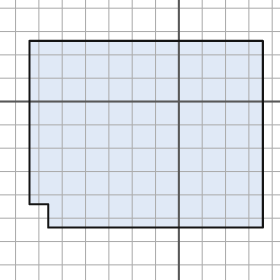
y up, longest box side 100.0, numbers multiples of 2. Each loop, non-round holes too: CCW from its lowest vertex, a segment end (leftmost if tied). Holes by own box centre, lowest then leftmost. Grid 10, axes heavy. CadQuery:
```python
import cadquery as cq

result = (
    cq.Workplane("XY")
    .moveTo(-56.0, -54.0)
    .lineTo(36.0, -54.0)
    .lineTo(36.0, 26.0)
    .lineTo(-64.0, 26.0)
    .lineTo(-64.0, -44.0)
    .lineTo(-56.0, -44.0)
    .close()
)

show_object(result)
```